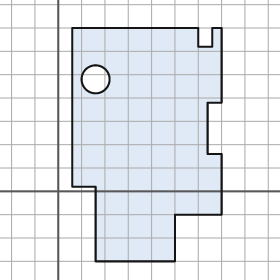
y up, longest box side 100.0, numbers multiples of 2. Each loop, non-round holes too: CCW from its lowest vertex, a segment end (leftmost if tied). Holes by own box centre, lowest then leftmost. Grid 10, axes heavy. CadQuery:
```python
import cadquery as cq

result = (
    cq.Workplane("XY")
    .moveTo(16.0, -30.0)
    .lineTo(50.0, -30.0)
    .lineTo(50.0, -10.0)
    .lineTo(70.0, -10.0)
    .lineTo(70.0, 16.0)
    .lineTo(64.0, 16.0)
    .lineTo(64.0, 38.0)
    .lineTo(70.0, 38.0)
    .lineTo(70.0, 70.0)
    .lineTo(66.0, 70.0)
    .lineTo(66.0, 62.0)
    .lineTo(60.0, 62.0)
    .lineTo(60.0, 70.0)
    .lineTo(6.0, 70.0)
    .lineTo(6.0, 2.0)
    .lineTo(16.0, 2.0)
    .close()
    .moveTo(16.0, 48.0)
    .circle(6.0)
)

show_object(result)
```